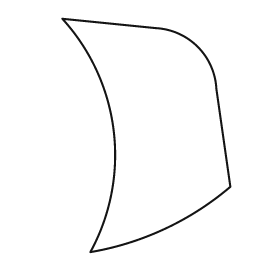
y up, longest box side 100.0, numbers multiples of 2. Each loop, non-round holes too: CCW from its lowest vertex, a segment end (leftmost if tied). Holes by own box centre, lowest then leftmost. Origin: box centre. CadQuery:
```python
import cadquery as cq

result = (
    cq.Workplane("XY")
    .moveTo(-24.0, -50.0)
    .threePointArc((8.0, -40.0), (36.0, -22.0))
    .lineTo(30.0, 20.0)
    .threePointArc((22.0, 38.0), (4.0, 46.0))
    .lineTo(-36.0, 50.0)
    .threePointArc((-14.0, 2.0), (-24.0, -50.0))
    .close()
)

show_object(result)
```